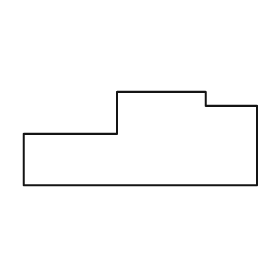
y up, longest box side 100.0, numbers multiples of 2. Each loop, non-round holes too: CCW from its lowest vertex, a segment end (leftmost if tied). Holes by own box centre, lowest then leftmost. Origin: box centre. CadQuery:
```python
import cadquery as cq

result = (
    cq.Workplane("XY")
    .moveTo(-50.0, -20.0)
    .lineTo(50.0, -20.0)
    .lineTo(50.0, 14.0)
    .lineTo(28.0, 14.0)
    .lineTo(28.0, 20.0)
    .lineTo(-10.0, 20.0)
    .lineTo(-10.0, 2.0)
    .lineTo(-50.0, 2.0)
    .close()
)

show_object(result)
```